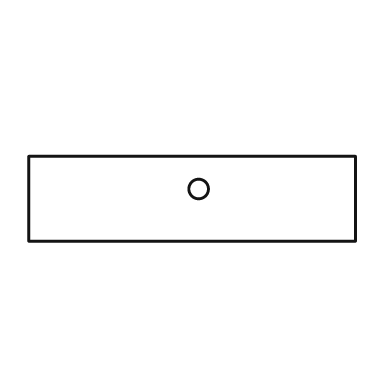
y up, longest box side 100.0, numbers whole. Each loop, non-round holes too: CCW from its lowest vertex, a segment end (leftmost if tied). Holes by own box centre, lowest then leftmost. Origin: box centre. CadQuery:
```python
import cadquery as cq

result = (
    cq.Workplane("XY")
    .moveTo(-50.0, -13.0)
    .lineTo(50.0, -13.0)
    .lineTo(50.0, 13.0)
    .lineTo(-50.0, 13.0)
    .close()
    .moveTo(2.0, 3.0)
    .circle(3.0)
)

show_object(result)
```